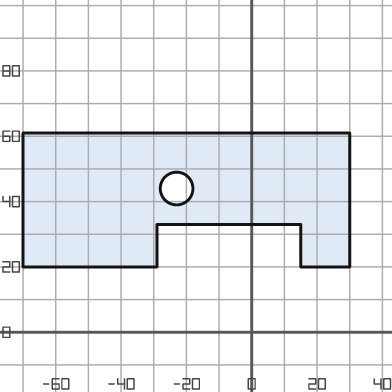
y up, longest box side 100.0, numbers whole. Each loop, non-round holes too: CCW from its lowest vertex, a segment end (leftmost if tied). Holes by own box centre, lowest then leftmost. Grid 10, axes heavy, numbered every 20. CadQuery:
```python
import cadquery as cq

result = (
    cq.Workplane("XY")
    .moveTo(-70.0, 20.0)
    .lineTo(-29.0, 20.0)
    .lineTo(-29.0, 33.0)
    .lineTo(15.0, 33.0)
    .lineTo(15.0, 20.0)
    .lineTo(30.0, 20.0)
    .lineTo(30.0, 61.0)
    .lineTo(-70.0, 61.0)
    .close()
    .moveTo(-23.0, 44.0)
    .circle(5.0)
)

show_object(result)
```